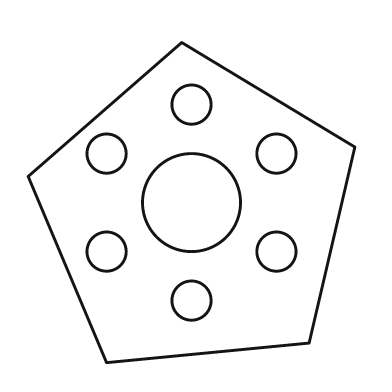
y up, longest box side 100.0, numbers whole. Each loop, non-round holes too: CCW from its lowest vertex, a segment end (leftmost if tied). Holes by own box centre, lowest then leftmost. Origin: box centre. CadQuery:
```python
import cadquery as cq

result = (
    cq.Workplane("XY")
    .moveTo(-26.0, -49.0)
    .lineTo(36.0, -43.0)
    .lineTo(50.0, 17.0)
    .lineTo(-3.0, 49.0)
    .lineTo(-50.0, 8.0)
    .close()
    .moveTo(0.0, -30.0)
    .circle(6.0)
    .moveTo(-26.0, -15.0)
    .circle(6.0)
    .moveTo(26.0, -15.0)
    .circle(6.0)
    .moveTo(0.0, 0.0)
    .circle(15.0)
    .moveTo(-26.0, 15.0)
    .circle(6.0)
    .moveTo(26.0, 15.0)
    .circle(6.0)
    .moveTo(0.0, 30.0)
    .circle(6.0)
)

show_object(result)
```